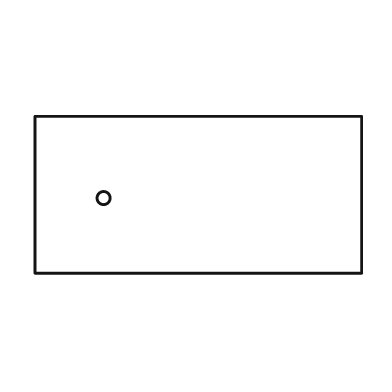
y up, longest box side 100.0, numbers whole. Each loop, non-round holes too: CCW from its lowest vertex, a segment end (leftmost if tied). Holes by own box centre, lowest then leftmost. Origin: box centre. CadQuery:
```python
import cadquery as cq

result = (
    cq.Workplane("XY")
    .moveTo(-50.0, -24.0)
    .lineTo(50.0, -24.0)
    .lineTo(50.0, 24.0)
    .lineTo(-50.0, 24.0)
    .close()
    .moveTo(-29.0, -1.0)
    .circle(2.0)
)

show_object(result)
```